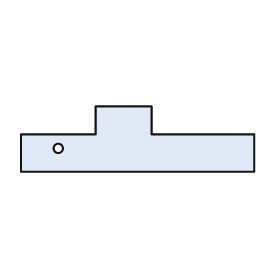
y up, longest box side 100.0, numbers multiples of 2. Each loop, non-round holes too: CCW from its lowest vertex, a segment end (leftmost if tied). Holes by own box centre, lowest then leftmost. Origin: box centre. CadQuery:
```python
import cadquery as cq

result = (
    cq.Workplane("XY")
    .moveTo(-50.0, -14.0)
    .lineTo(50.0, -14.0)
    .lineTo(50.0, 2.0)
    .lineTo(6.0, 2.0)
    .lineTo(6.0, 14.0)
    .lineTo(-18.0, 14.0)
    .lineTo(-18.0, 2.0)
    .lineTo(-50.0, 2.0)
    .close()
    .moveTo(-34.0, -4.0)
    .circle(2.0)
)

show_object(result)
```